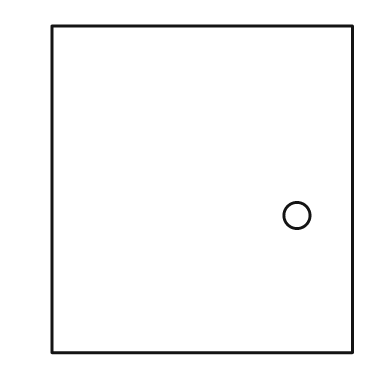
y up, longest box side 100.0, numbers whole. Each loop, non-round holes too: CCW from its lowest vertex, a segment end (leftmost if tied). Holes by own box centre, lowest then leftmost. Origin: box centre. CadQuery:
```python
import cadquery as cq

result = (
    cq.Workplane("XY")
    .moveTo(-46.0, -50.0)
    .lineTo(46.0, -50.0)
    .lineTo(46.0, 50.0)
    .lineTo(-46.0, 50.0)
    .close()
    .moveTo(29.0, -8.0)
    .circle(4.0)
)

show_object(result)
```